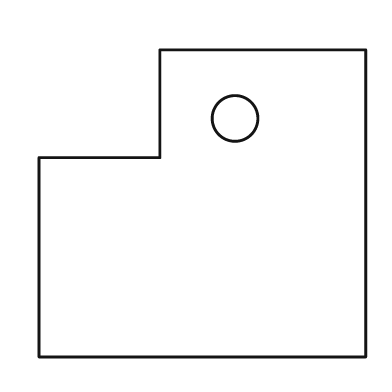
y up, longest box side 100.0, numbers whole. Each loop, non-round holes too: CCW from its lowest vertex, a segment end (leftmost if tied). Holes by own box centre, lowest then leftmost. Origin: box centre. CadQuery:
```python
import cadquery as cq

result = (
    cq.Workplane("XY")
    .moveTo(-50.0, -47.0)
    .lineTo(50.0, -47.0)
    .lineTo(50.0, 47.0)
    .lineTo(-13.0, 47.0)
    .lineTo(-13.0, 14.0)
    .lineTo(-50.0, 14.0)
    .close()
    .moveTo(10.0, 26.0)
    .circle(7.0)
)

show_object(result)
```